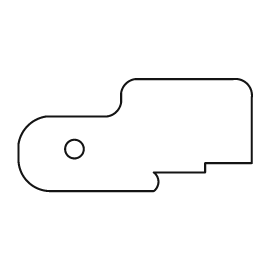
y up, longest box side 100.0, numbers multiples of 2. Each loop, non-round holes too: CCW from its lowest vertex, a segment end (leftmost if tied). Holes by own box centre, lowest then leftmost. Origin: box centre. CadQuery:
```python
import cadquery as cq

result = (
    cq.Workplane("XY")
    .moveTo(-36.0, -24.0)
    .lineTo(8.0, -24.0)
    .threePointArc((10.0, -20.0), (8.0, -16.0))
    .lineTo(30.0, -16.0)
    .lineTo(30.0, -12.0)
    .lineTo(50.0, -12.0)
    .lineTo(50.0, 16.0)
    .threePointArc((48.0, 22.0), (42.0, 24.0))
    .lineTo(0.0, 24.0)
    .threePointArc((-4.0, 22.0), (-6.0, 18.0))
    .lineTo(-6.0, 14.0)
    .threePointArc((-8.0, 10.0), (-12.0, 8.0))
    .lineTo(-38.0, 8.0)
    .threePointArc((-46.0, 4.0), (-50.0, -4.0))
    .lineTo(-50.0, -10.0)
    .threePointArc((-46.0, -20.0), (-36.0, -24.0))
    .close()
    .moveTo(-26.0, -6.0)
    .circle(4.0)
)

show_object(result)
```